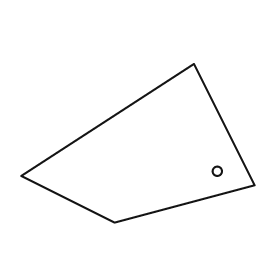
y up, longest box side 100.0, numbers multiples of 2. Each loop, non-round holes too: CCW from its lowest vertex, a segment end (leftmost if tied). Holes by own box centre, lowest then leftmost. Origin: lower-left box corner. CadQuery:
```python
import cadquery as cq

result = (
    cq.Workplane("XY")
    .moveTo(40.0, 0.0)
    .lineTo(100.0, 16.0)
    .lineTo(74.0, 68.0)
    .lineTo(0.0, 20.0)
    .close()
    .moveTo(84.0, 22.0)
    .circle(2.0)
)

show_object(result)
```